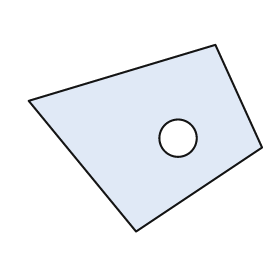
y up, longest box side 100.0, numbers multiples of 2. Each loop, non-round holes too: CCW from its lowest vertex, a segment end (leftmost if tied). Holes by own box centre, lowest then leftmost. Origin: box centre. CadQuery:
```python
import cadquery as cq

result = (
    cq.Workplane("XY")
    .moveTo(-4.0, -40.0)
    .lineTo(50.0, -4.0)
    .lineTo(30.0, 40.0)
    .lineTo(-50.0, 16.0)
    .close()
    .moveTo(14.0, 0.0)
    .circle(8.0)
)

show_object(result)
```